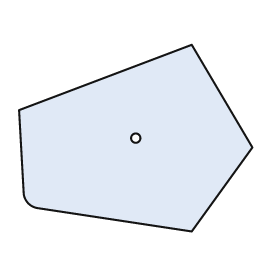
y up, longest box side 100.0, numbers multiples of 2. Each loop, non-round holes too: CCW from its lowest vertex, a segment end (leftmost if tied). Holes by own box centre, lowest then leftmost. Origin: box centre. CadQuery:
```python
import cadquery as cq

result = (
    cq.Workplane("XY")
    .moveTo(24.0, -40.0)
    .lineTo(50.0, -4.0)
    .lineTo(24.0, 40.0)
    .lineTo(-50.0, 12.0)
    .lineTo(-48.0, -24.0)
    .threePointArc((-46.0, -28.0), (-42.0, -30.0))
    .close()
    .moveTo(0.0, 0.0)
    .circle(2.0)
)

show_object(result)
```